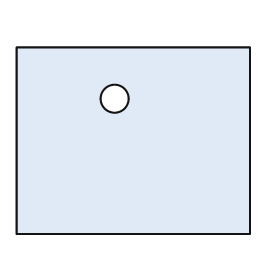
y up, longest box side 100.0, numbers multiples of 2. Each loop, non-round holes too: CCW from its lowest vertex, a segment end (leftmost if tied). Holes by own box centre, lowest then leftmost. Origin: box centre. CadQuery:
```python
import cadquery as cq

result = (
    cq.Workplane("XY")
    .moveTo(-50.0, -40.0)
    .lineTo(50.0, -40.0)
    .lineTo(50.0, 40.0)
    .lineTo(-50.0, 40.0)
    .close()
    .moveTo(-8.0, 18.0)
    .circle(6.0)
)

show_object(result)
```